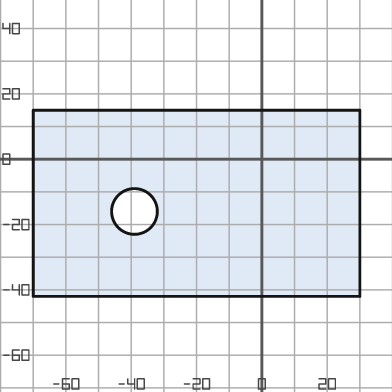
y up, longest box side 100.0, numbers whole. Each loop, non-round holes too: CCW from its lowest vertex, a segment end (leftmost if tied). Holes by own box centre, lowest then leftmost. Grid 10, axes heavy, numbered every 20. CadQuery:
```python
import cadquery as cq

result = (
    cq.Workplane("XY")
    .moveTo(-70.0, -42.0)
    .lineTo(30.0, -42.0)
    .lineTo(30.0, 15.0)
    .lineTo(-70.0, 15.0)
    .close()
    .moveTo(-39.0, -16.0)
    .circle(7.0)
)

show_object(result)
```